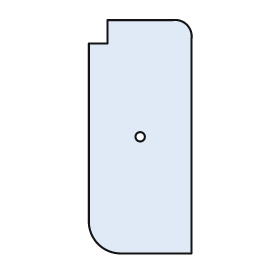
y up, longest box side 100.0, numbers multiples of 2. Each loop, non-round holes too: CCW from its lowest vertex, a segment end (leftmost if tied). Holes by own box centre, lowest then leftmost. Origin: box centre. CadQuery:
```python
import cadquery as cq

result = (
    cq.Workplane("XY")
    .moveTo(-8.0, -50.0)
    .lineTo(22.0, -50.0)
    .lineTo(22.0, 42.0)
    .threePointArc((20.0, 48.0), (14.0, 50.0))
    .lineTo(-14.0, 50.0)
    .lineTo(-14.0, 40.0)
    .lineTo(-22.0, 40.0)
    .lineTo(-22.0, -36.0)
    .threePointArc((-18.0, -46.0), (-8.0, -50.0))
    .close()
    .moveTo(0.0, 0.0)
    .circle(2.0)
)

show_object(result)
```